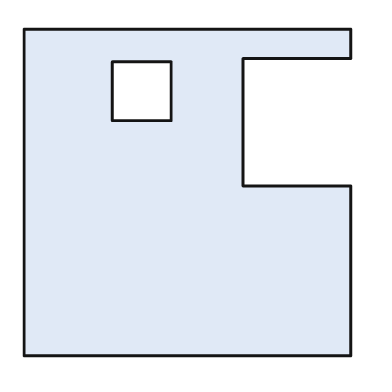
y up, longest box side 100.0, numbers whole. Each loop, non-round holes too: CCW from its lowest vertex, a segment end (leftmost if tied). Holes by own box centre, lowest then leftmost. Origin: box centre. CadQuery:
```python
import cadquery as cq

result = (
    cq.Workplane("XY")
    .moveTo(-50.0, -50.0)
    .lineTo(50.0, -50.0)
    .lineTo(50.0, 2.0)
    .lineTo(17.0, 2.0)
    .lineTo(17.0, 41.0)
    .lineTo(50.0, 41.0)
    .lineTo(50.0, 50.0)
    .lineTo(-50.0, 50.0)
    .close()
    .moveTo(-23.0, 22.0)
    .lineTo(-5.0, 22.0)
    .lineTo(-5.0, 40.0)
    .lineTo(-23.0, 40.0)
    .close()
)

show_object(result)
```